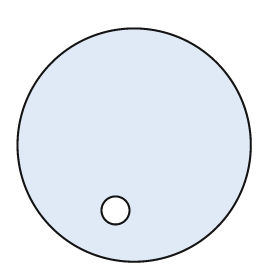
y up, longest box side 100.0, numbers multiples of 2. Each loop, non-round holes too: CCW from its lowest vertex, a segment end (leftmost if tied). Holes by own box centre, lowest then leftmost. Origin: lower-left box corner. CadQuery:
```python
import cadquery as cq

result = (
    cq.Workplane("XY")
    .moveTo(50.0, 50.0)
    .circle(50.0)
    .moveTo(42.0, 22.0)
    .circle(6.0)
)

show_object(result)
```